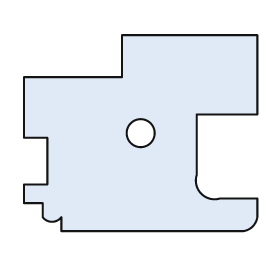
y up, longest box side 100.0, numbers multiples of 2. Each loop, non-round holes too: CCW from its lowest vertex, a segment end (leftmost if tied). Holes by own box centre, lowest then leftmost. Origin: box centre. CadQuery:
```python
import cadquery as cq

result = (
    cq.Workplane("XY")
    .moveTo(-34.0, -42.0)
    .lineTo(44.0, -42.0)
    .threePointArc((48.0, -40.0), (50.0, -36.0))
    .lineTo(50.0, -28.0)
    .lineTo(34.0, -28.0)
    .threePointArc((26.0, -26.0), (24.0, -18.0))
    .lineTo(24.0, 8.0)
    .lineTo(50.0, 8.0)
    .lineTo(50.0, 42.0)
    .lineTo(-8.0, 42.0)
    .lineTo(-8.0, 24.0)
    .lineTo(-50.0, 24.0)
    .lineTo(-50.0, -2.0)
    .lineTo(-40.0, -2.0)
    .lineTo(-40.0, -22.0)
    .lineTo(-50.0, -22.0)
    .lineTo(-50.0, -30.0)
    .lineTo(-42.0, -30.0)
    .lineTo(-42.0, -36.0)
    .threePointArc((-38.0, -38.0), (-34.0, -36.0))
    .close()
    .moveTo(0.0, 0.0)
    .circle(6.0)
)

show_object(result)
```